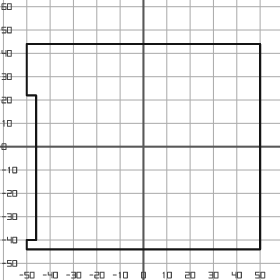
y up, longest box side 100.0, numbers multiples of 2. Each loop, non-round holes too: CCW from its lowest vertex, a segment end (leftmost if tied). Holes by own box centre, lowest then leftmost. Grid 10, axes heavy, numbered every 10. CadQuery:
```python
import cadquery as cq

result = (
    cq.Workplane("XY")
    .moveTo(-50.0, -44.0)
    .lineTo(50.0, -44.0)
    .lineTo(50.0, 44.0)
    .lineTo(-50.0, 44.0)
    .lineTo(-50.0, 22.0)
    .lineTo(-46.0, 22.0)
    .lineTo(-46.0, -40.0)
    .lineTo(-50.0, -40.0)
    .close()
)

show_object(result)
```